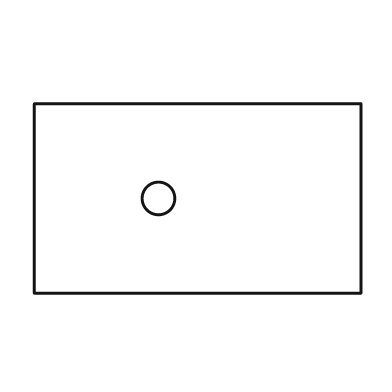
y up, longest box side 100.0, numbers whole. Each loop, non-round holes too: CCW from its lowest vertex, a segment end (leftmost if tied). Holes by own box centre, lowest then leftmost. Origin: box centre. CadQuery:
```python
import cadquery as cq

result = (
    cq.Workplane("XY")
    .moveTo(-50.0, -29.0)
    .lineTo(50.0, -29.0)
    .lineTo(50.0, 29.0)
    .lineTo(-50.0, 29.0)
    .close()
    .moveTo(-12.0, 0.0)
    .circle(5.0)
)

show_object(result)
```